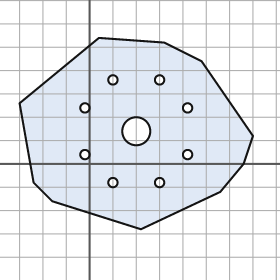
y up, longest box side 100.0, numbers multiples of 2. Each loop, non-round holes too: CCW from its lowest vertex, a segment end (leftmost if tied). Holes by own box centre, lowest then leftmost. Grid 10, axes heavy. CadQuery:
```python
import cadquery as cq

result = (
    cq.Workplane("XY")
    .moveTo(22.0, -28.0)
    .lineTo(56.0, -12.0)
    .lineTo(66.0, 0.0)
    .lineTo(70.0, 12.0)
    .lineTo(48.0, 44.0)
    .lineTo(32.0, 52.0)
    .lineTo(4.0, 54.0)
    .lineTo(-30.0, 26.0)
    .lineTo(-24.0, -8.0)
    .lineTo(-16.0, -16.0)
    .close()
    .moveTo(10.0, -8.0)
    .circle(2.0)
    .moveTo(30.0, -8.0)
    .circle(2.0)
    .moveTo(-2.0, 4.0)
    .circle(2.0)
    .moveTo(42.0, 4.0)
    .circle(2.0)
    .moveTo(20.0, 14.0)
    .circle(6.0)
    .moveTo(-2.0, 24.0)
    .circle(2.0)
    .moveTo(42.0, 24.0)
    .circle(2.0)
    .moveTo(10.0, 36.0)
    .circle(2.0)
    .moveTo(30.0, 36.0)
    .circle(2.0)
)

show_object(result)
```